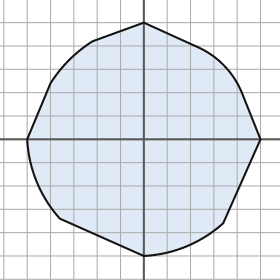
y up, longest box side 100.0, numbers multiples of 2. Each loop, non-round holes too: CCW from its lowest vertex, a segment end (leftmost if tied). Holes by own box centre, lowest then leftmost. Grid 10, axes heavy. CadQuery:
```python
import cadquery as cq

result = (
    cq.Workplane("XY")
    .moveTo(0.0, -50.0)
    .threePointArc((18.0, -46.0), (34.0, -36.0))
    .lineTo(50.0, 0.0)
    .lineTo(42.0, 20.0)
    .threePointArc((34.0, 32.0), (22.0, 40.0))
    .lineTo(0.0, 50.0)
    .lineTo(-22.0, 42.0)
    .threePointArc((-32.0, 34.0), (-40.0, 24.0))
    .lineTo(-50.0, 0.0)
    .threePointArc((-46.0, -18.0), (-36.0, -34.0))
    .close()
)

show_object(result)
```